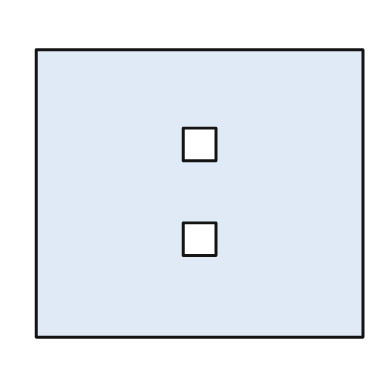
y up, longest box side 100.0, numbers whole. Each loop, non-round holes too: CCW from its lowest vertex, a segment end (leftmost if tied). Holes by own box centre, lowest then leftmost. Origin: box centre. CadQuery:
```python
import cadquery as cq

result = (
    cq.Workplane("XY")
    .moveTo(-50.0, -44.0)
    .lineTo(50.0, -44.0)
    .lineTo(50.0, 44.0)
    .lineTo(-50.0, 44.0)
    .close()
    .moveTo(-5.0, -19.0)
    .lineTo(5.0, -19.0)
    .lineTo(5.0, -9.0)
    .lineTo(-5.0, -9.0)
    .close()
    .moveTo(-5.0, 10.0)
    .lineTo(5.0, 10.0)
    .lineTo(5.0, 20.0)
    .lineTo(-5.0, 20.0)
    .close()
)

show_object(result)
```